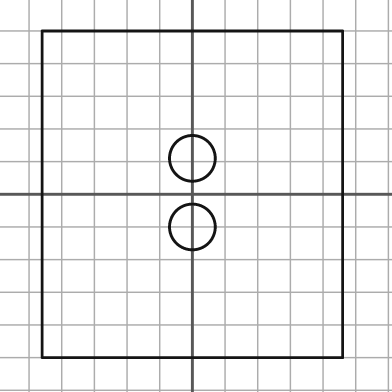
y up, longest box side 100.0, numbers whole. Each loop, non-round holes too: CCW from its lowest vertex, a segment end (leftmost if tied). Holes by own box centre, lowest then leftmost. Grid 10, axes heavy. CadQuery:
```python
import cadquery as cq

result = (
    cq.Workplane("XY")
    .moveTo(-46.0, -50.0)
    .lineTo(46.0, -50.0)
    .lineTo(46.0, 50.0)
    .lineTo(-46.0, 50.0)
    .close()
    .moveTo(0.0, -10.0)
    .circle(7.0)
    .moveTo(0.0, 11.0)
    .circle(7.0)
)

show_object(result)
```